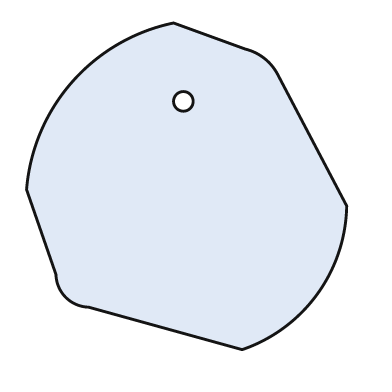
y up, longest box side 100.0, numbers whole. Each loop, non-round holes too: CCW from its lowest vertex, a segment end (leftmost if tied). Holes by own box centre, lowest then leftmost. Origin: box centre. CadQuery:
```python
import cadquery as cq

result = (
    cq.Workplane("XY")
    .moveTo(17.0, -50.0)
    .threePointArc((40.0, -33.0), (49.0, -6.0))
    .lineTo(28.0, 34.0)
    .threePointArc((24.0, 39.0), (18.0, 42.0))
    .lineTo(-4.0, 50.0)
    .threePointArc((-35.0, 32.0), (-49.0, -1.0))
    .lineTo(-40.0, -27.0)
    .threePointArc((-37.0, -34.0), (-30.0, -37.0))
    .close()
    .moveTo(-1.0, 26.0)
    .circle(3.0)
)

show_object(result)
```